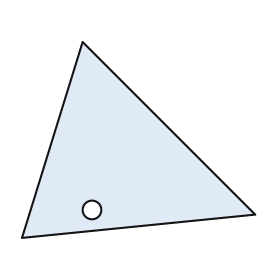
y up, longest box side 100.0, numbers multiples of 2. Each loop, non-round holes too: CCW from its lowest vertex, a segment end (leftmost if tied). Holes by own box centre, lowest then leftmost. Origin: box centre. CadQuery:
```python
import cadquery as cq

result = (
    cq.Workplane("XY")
    .moveTo(-50.0, -42.0)
    .lineTo(50.0, -32.0)
    .lineTo(-24.0, 42.0)
    .close()
    .moveTo(-20.0, -30.0)
    .circle(4.0)
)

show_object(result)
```